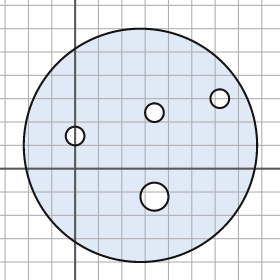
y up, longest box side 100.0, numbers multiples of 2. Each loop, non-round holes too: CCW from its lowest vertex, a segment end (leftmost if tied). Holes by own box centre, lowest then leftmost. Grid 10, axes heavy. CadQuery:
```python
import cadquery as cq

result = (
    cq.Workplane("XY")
    .moveTo(28.0, 10.0)
    .circle(50.0)
    .moveTo(34.0, -12.0)
    .circle(6.0)
    .moveTo(0.0, 14.0)
    .circle(4.0)
    .moveTo(34.0, 24.0)
    .circle(4.0)
    .moveTo(62.0, 30.0)
    .circle(4.0)
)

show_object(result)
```